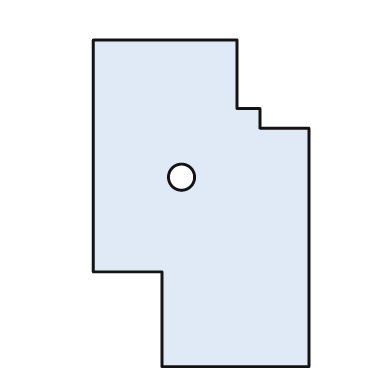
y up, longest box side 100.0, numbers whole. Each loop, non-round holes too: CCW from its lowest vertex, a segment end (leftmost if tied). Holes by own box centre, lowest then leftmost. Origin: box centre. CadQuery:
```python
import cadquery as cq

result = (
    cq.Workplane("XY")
    .moveTo(-12.0, -50.0)
    .lineTo(33.0, -50.0)
    .lineTo(33.0, 23.0)
    .lineTo(18.0, 23.0)
    .lineTo(18.0, 29.0)
    .lineTo(11.0, 29.0)
    .lineTo(11.0, 50.0)
    .lineTo(-33.0, 50.0)
    .lineTo(-33.0, -21.0)
    .lineTo(-12.0, -21.0)
    .close()
    .moveTo(-6.0, 8.0)
    .circle(4.0)
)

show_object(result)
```